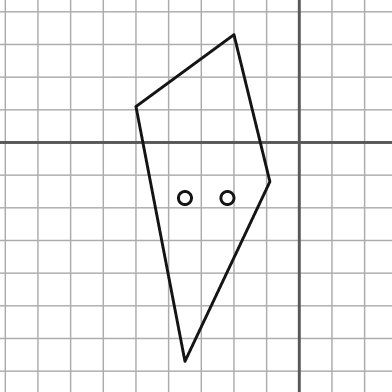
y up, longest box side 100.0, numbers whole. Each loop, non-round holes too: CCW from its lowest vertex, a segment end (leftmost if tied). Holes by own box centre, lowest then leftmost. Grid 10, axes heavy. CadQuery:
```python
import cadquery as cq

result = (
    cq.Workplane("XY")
    .moveTo(-35.0, -67.0)
    .lineTo(-9.0, -12.0)
    .lineTo(-20.0, 33.0)
    .lineTo(-50.0, 11.0)
    .close()
    .moveTo(-35.0, -17.0)
    .circle(2.0)
    .moveTo(-22.0, -17.0)
    .circle(2.0)
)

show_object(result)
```